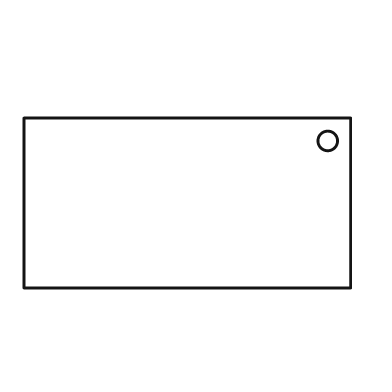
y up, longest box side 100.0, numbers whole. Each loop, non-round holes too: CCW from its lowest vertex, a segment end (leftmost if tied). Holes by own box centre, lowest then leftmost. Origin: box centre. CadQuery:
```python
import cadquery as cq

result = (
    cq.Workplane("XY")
    .moveTo(-50.0, -26.0)
    .lineTo(50.0, -26.0)
    .lineTo(50.0, 26.0)
    .lineTo(-50.0, 26.0)
    .close()
    .moveTo(43.0, 19.0)
    .circle(3.0)
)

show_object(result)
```